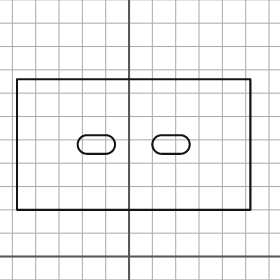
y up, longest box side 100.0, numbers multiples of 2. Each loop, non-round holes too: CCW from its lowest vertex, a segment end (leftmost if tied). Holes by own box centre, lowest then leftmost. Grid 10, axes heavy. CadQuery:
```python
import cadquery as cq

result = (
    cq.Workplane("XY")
    .moveTo(-48.0, 20.0)
    .lineTo(52.0, 20.0)
    .lineTo(52.0, 76.0)
    .lineTo(-48.0, 76.0)
    .close()
    .moveTo(-18.0, 44.0)
    .lineTo(-10.0, 44.0)
    .threePointArc((-6.0, 48.0), (-10.0, 52.0))
    .lineTo(-18.0, 52.0)
    .threePointArc((-22.0, 48.0), (-18.0, 44.0))
    .close()
    .moveTo(14.0, 44.0)
    .lineTo(22.0, 44.0)
    .threePointArc((26.0, 48.0), (22.0, 52.0))
    .lineTo(14.0, 52.0)
    .threePointArc((10.0, 48.0), (14.0, 44.0))
    .close()
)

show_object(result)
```